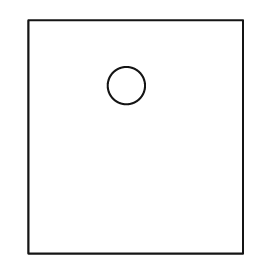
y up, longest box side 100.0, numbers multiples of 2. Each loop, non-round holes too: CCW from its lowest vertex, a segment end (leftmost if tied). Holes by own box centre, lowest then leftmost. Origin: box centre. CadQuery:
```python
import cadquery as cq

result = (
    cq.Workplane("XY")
    .moveTo(-46.0, -50.0)
    .lineTo(46.0, -50.0)
    .lineTo(46.0, 50.0)
    .lineTo(-46.0, 50.0)
    .close()
    .moveTo(-4.0, 22.0)
    .circle(8.0)
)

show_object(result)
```